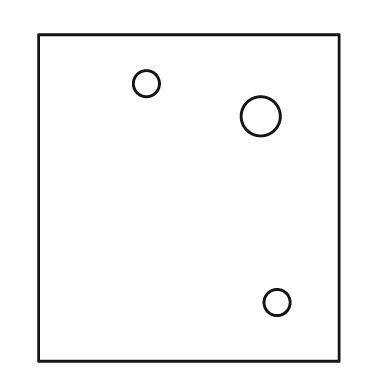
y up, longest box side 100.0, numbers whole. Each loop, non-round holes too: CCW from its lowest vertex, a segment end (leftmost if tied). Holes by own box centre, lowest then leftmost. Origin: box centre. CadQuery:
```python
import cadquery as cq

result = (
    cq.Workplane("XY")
    .moveTo(-46.0, -50.0)
    .lineTo(46.0, -50.0)
    .lineTo(46.0, 50.0)
    .lineTo(-46.0, 50.0)
    .close()
    .moveTo(27.0, -32.0)
    .circle(4.0)
    .moveTo(22.0, 25.0)
    .circle(6.0)
    .moveTo(-13.0, 35.0)
    .circle(4.0)
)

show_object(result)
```